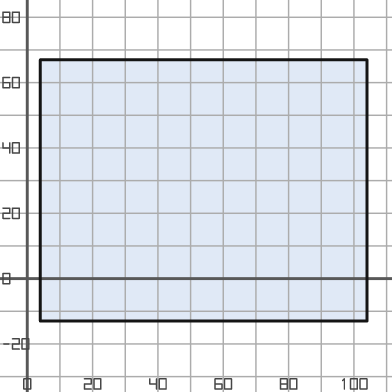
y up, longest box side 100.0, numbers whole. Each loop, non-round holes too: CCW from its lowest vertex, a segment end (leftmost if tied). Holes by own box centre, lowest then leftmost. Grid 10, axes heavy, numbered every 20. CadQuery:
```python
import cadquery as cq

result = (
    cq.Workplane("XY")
    .moveTo(4.0, -13.0)
    .lineTo(104.0, -13.0)
    .lineTo(104.0, 67.0)
    .lineTo(4.0, 67.0)
    .close()
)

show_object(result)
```